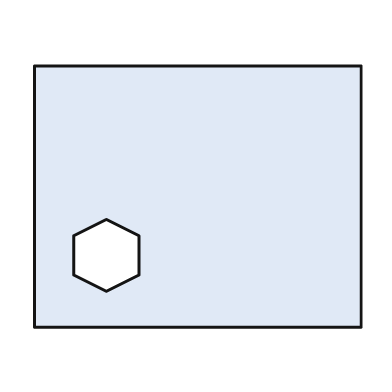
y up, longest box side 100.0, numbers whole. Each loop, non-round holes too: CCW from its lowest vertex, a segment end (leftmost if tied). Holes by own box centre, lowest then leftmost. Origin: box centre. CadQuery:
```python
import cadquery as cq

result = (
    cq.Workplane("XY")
    .moveTo(-50.0, -40.0)
    .lineTo(50.0, -40.0)
    .lineTo(50.0, 40.0)
    .lineTo(-50.0, 40.0)
    .close()
    .moveTo(-28.0, -29.0)
    .lineTo(-18.0, -24.0)
    .lineTo(-18.0, -12.0)
    .lineTo(-28.0, -7.0)
    .lineTo(-38.0, -12.0)
    .lineTo(-38.0, -24.0)
    .close()
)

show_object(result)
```